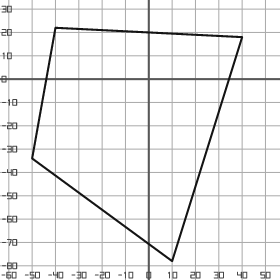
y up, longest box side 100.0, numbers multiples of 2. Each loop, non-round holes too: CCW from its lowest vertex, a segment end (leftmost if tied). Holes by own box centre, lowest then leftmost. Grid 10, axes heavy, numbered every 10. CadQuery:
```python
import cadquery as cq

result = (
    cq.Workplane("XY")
    .moveTo(10.0, -78.0)
    .lineTo(40.0, 18.0)
    .lineTo(-40.0, 22.0)
    .lineTo(-50.0, -34.0)
    .close()
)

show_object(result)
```